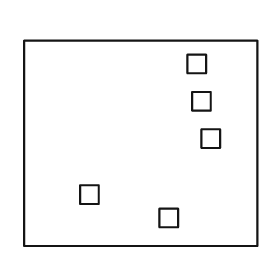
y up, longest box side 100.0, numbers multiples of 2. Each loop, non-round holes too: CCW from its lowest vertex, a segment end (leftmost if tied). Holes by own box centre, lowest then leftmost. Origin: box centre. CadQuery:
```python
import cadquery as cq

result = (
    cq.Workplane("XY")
    .moveTo(-50.0, -44.0)
    .lineTo(50.0, -44.0)
    .lineTo(50.0, 44.0)
    .lineTo(-50.0, 44.0)
    .close()
    .moveTo(8.0, -36.0)
    .lineTo(16.0, -36.0)
    .lineTo(16.0, -28.0)
    .lineTo(8.0, -28.0)
    .close()
    .moveTo(-26.0, -26.0)
    .lineTo(-18.0, -26.0)
    .lineTo(-18.0, -18.0)
    .lineTo(-26.0, -18.0)
    .close()
    .moveTo(26.0, -2.0)
    .lineTo(34.0, -2.0)
    .lineTo(34.0, 6.0)
    .lineTo(26.0, 6.0)
    .close()
    .moveTo(22.0, 14.0)
    .lineTo(30.0, 14.0)
    .lineTo(30.0, 22.0)
    .lineTo(22.0, 22.0)
    .close()
    .moveTo(20.0, 30.0)
    .lineTo(28.0, 30.0)
    .lineTo(28.0, 38.0)
    .lineTo(20.0, 38.0)
    .close()
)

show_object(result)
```